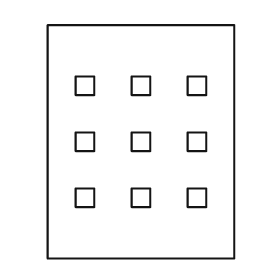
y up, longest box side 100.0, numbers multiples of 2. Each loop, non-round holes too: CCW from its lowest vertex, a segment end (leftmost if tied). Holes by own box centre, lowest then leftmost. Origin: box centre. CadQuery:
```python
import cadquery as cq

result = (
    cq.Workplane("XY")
    .moveTo(-40.0, -50.0)
    .lineTo(40.0, -50.0)
    .lineTo(40.0, 50.0)
    .lineTo(-40.0, 50.0)
    .close()
    .moveTo(-28.0, -28.0)
    .lineTo(-20.0, -28.0)
    .lineTo(-20.0, -20.0)
    .lineTo(-28.0, -20.0)
    .close()
    .moveTo(-4.0, -28.0)
    .lineTo(4.0, -28.0)
    .lineTo(4.0, -20.0)
    .lineTo(-4.0, -20.0)
    .close()
    .moveTo(20.0, -28.0)
    .lineTo(28.0, -28.0)
    .lineTo(28.0, -20.0)
    .lineTo(20.0, -20.0)
    .close()
    .moveTo(-28.0, -4.0)
    .lineTo(-20.0, -4.0)
    .lineTo(-20.0, 4.0)
    .lineTo(-28.0, 4.0)
    .close()
    .moveTo(-4.0, -4.0)
    .lineTo(4.0, -4.0)
    .lineTo(4.0, 4.0)
    .lineTo(-4.0, 4.0)
    .close()
    .moveTo(20.0, -4.0)
    .lineTo(28.0, -4.0)
    .lineTo(28.0, 4.0)
    .lineTo(20.0, 4.0)
    .close()
    .moveTo(-28.0, 20.0)
    .lineTo(-20.0, 20.0)
    .lineTo(-20.0, 28.0)
    .lineTo(-28.0, 28.0)
    .close()
    .moveTo(-4.0, 20.0)
    .lineTo(4.0, 20.0)
    .lineTo(4.0, 28.0)
    .lineTo(-4.0, 28.0)
    .close()
    .moveTo(20.0, 20.0)
    .lineTo(28.0, 20.0)
    .lineTo(28.0, 28.0)
    .lineTo(20.0, 28.0)
    .close()
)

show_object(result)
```